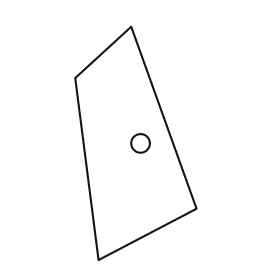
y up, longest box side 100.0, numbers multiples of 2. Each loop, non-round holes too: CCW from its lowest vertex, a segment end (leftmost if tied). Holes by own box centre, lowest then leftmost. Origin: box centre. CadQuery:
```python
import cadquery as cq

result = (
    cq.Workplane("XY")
    .moveTo(-16.0, -50.0)
    .lineTo(26.0, -28.0)
    .lineTo(-2.0, 50.0)
    .lineTo(-26.0, 28.0)
    .close()
    .moveTo(2.0, 0.0)
    .circle(4.0)
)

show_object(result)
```